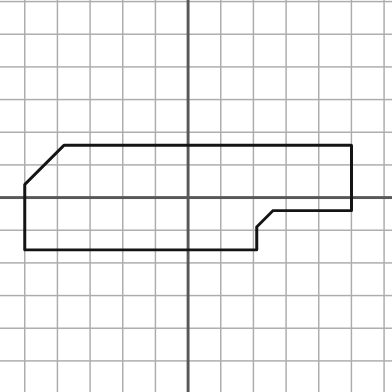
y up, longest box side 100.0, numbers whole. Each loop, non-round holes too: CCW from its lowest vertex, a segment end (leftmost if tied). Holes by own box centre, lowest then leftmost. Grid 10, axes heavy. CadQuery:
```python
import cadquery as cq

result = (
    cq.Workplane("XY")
    .moveTo(-50.0, -16.0)
    .lineTo(21.0, -16.0)
    .lineTo(21.0, -9.0)
    .lineTo(26.0, -4.0)
    .lineTo(50.0, -4.0)
    .lineTo(50.0, 16.0)
    .lineTo(-38.0, 16.0)
    .lineTo(-50.0, 4.0)
    .close()
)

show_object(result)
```